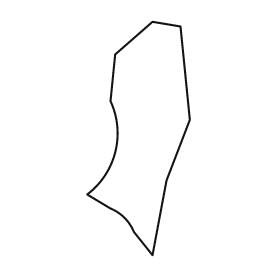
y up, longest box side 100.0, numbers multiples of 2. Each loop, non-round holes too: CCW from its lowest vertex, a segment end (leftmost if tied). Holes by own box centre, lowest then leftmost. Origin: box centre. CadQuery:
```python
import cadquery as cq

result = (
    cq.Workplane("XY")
    .moveTo(6.0, -50.0)
    .lineTo(12.0, -18.0)
    .lineTo(22.0, 8.0)
    .lineTo(18.0, 48.0)
    .lineTo(6.0, 50.0)
    .lineTo(-10.0, 36.0)
    .lineTo(-12.0, 16.0)
    .threePointArc((-10.0, -6.0), (-22.0, -24.0))
    .lineTo(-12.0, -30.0)
    .threePointArc((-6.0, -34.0), (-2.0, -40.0))
    .close()
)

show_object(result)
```